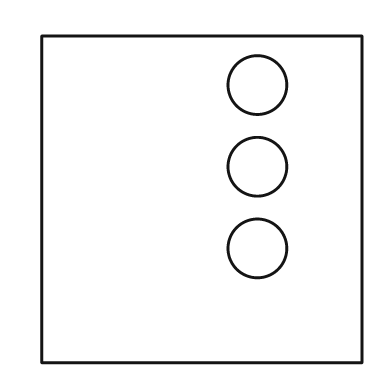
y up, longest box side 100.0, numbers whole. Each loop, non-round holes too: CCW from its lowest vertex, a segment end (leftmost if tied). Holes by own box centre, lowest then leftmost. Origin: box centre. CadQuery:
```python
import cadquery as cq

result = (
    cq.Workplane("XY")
    .moveTo(-49.0, -50.0)
    .lineTo(49.0, -50.0)
    .lineTo(49.0, 50.0)
    .lineTo(-49.0, 50.0)
    .close()
    .moveTo(17.0, -15.0)
    .circle(9.0)
    .moveTo(17.0, 10.0)
    .circle(9.0)
    .moveTo(17.0, 35.0)
    .circle(9.0)
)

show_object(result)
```